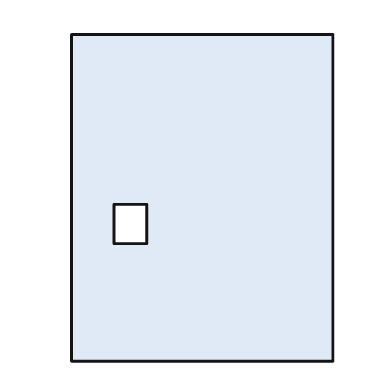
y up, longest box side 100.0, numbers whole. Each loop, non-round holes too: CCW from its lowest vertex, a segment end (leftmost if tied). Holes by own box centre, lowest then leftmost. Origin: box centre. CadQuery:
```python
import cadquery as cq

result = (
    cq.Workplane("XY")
    .moveTo(-40.0, -50.0)
    .lineTo(40.0, -50.0)
    .lineTo(40.0, 50.0)
    .lineTo(-40.0, 50.0)
    .close()
    .moveTo(-27.0, -14.0)
    .lineTo(-17.0, -14.0)
    .lineTo(-17.0, -2.0)
    .lineTo(-27.0, -2.0)
    .close()
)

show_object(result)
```